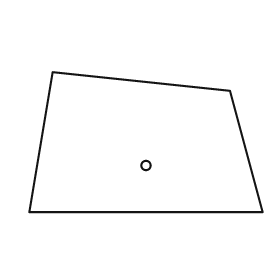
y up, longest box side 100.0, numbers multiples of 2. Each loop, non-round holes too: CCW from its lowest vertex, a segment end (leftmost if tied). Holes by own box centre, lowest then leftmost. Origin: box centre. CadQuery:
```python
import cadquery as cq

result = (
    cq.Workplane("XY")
    .moveTo(-50.0, -30.0)
    .lineTo(50.0, -30.0)
    .lineTo(36.0, 22.0)
    .lineTo(-40.0, 30.0)
    .close()
    .moveTo(0.0, -10.0)
    .circle(2.0)
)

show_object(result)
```